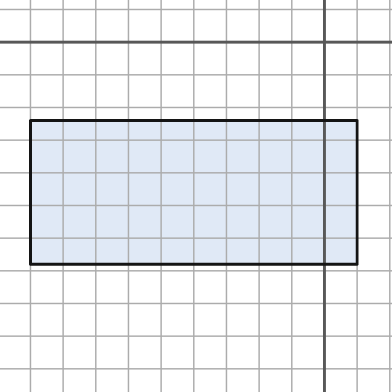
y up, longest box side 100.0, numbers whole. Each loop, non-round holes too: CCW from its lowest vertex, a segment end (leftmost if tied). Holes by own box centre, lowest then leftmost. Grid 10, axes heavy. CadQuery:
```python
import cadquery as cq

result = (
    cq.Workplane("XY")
    .moveTo(-90.0, -68.0)
    .lineTo(10.0, -68.0)
    .lineTo(10.0, -24.0)
    .lineTo(-90.0, -24.0)
    .close()
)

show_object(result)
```